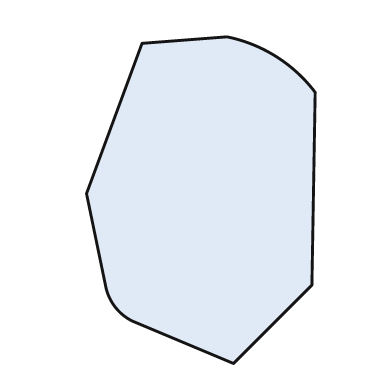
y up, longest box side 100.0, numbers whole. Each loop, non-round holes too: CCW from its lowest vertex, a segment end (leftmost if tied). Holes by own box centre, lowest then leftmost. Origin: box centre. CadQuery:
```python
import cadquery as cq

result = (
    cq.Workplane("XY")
    .moveTo(10.0, -50.0)
    .lineTo(34.0, -26.0)
    .lineTo(35.0, 33.0)
    .threePointArc((23.0, 44.0), (8.0, 50.0))
    .lineTo(-18.0, 48.0)
    .lineTo(-35.0, 2.0)
    .lineTo(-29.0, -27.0)
    .threePointArc((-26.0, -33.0), (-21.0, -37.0))
    .close()
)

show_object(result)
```